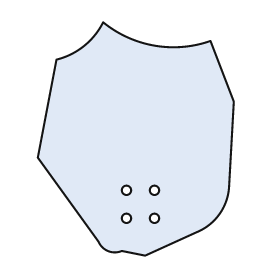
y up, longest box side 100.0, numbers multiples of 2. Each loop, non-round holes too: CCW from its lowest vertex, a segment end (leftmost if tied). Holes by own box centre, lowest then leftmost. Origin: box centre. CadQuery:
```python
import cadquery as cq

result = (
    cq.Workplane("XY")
    .moveTo(4.0, -50.0)
    .lineTo(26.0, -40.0)
    .threePointArc((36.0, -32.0), (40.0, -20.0))
    .lineTo(42.0, 16.0)
    .lineTo(32.0, 42.0)
    .threePointArc((8.0, 40.0), (-14.0, 50.0))
    .threePointArc((-22.0, 40.0), (-34.0, 34.0))
    .lineTo(-42.0, -8.0)
    .lineTo(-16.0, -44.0)
    .threePointArc((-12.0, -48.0), (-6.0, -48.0))
    .close()
    .moveTo(-4.0, -34.0)
    .circle(2.0)
    .moveTo(8.0, -34.0)
    .circle(2.0)
    .moveTo(-4.0, -22.0)
    .circle(2.0)
    .moveTo(8.0, -22.0)
    .circle(2.0)
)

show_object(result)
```